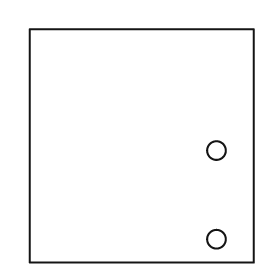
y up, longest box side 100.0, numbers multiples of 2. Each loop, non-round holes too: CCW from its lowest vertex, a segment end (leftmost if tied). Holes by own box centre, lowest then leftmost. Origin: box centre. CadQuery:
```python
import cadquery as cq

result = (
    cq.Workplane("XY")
    .moveTo(-48.0, -50.0)
    .lineTo(48.0, -50.0)
    .lineTo(48.0, 50.0)
    .lineTo(-48.0, 50.0)
    .close()
    .moveTo(32.0, -40.0)
    .circle(4.0)
    .moveTo(32.0, -2.0)
    .circle(4.0)
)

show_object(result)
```